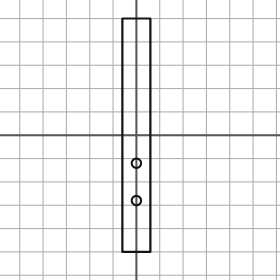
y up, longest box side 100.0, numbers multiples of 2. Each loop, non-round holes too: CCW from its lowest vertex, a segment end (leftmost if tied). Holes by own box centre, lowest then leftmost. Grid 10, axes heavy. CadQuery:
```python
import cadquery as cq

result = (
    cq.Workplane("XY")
    .moveTo(-6.0, -50.0)
    .lineTo(6.0, -50.0)
    .lineTo(6.0, 50.0)
    .lineTo(-6.0, 50.0)
    .close()
    .moveTo(0.0, -28.0)
    .circle(2.0)
    .moveTo(0.0, -12.0)
    .circle(2.0)
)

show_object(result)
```